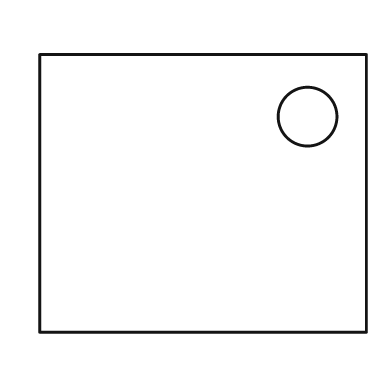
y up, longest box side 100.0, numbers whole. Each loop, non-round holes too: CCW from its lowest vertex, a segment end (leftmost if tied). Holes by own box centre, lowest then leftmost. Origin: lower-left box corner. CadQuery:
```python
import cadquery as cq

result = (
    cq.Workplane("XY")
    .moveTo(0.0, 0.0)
    .lineTo(100.0, 0.0)
    .lineTo(100.0, 85.0)
    .lineTo(0.0, 85.0)
    .close()
    .moveTo(82.0, 66.0)
    .circle(9.0)
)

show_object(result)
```